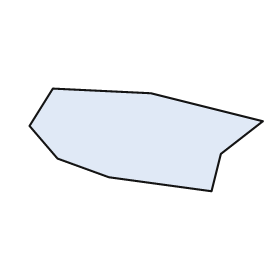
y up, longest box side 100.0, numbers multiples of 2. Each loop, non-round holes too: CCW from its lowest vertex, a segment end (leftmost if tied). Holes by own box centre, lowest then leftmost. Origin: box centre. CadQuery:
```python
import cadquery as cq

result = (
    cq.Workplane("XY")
    .moveTo(28.0, -22.0)
    .lineTo(32.0, -6.0)
    .lineTo(50.0, 8.0)
    .lineTo(2.0, 20.0)
    .lineTo(-40.0, 22.0)
    .lineTo(-50.0, 6.0)
    .lineTo(-38.0, -8.0)
    .lineTo(-16.0, -16.0)
    .close()
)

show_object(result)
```